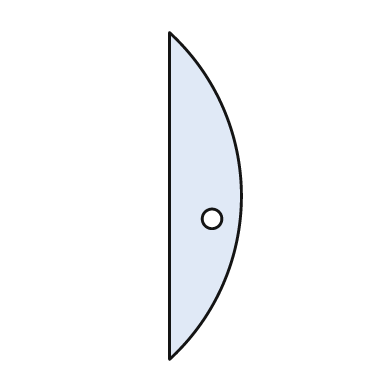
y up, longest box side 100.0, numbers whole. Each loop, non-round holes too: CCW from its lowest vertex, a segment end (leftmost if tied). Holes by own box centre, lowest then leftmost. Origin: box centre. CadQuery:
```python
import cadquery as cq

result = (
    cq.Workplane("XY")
    .moveTo(-11.0, -50.0)
    .threePointArc((11.0, 0.0), (-11.0, 50.0))
    .close()
    .moveTo(2.0, -7.0)
    .circle(3.0)
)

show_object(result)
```